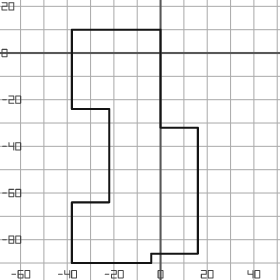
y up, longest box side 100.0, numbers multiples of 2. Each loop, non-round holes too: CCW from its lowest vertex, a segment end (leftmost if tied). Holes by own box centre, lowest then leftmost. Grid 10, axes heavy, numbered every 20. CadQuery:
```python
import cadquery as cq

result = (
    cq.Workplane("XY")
    .moveTo(-38.0, -90.0)
    .lineTo(-4.0, -90.0)
    .lineTo(-4.0, -86.0)
    .lineTo(16.0, -86.0)
    .lineTo(16.0, -32.0)
    .lineTo(0.0, -32.0)
    .lineTo(0.0, 10.0)
    .lineTo(-38.0, 10.0)
    .lineTo(-38.0, -24.0)
    .lineTo(-22.0, -24.0)
    .lineTo(-22.0, -64.0)
    .lineTo(-38.0, -64.0)
    .close()
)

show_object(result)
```